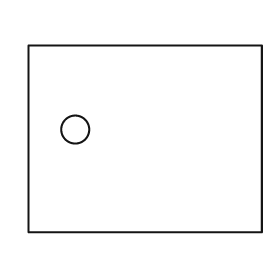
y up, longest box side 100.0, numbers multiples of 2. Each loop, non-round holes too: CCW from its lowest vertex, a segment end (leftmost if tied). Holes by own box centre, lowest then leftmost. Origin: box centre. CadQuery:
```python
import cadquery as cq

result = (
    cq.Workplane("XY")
    .moveTo(-50.0, -40.0)
    .lineTo(50.0, -40.0)
    .lineTo(50.0, 40.0)
    .lineTo(-50.0, 40.0)
    .close()
    .moveTo(-30.0, 4.0)
    .circle(6.0)
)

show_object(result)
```